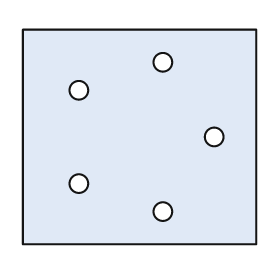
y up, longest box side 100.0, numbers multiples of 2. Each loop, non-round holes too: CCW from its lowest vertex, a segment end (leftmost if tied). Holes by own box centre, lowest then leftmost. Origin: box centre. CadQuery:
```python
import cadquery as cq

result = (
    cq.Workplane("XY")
    .moveTo(-50.0, -46.0)
    .lineTo(50.0, -46.0)
    .lineTo(50.0, 46.0)
    .lineTo(-50.0, 46.0)
    .close()
    .moveTo(10.0, -32.0)
    .circle(4.0)
    .moveTo(-26.0, -20.0)
    .circle(4.0)
    .moveTo(32.0, 0.0)
    .circle(4.0)
    .moveTo(-26.0, 20.0)
    .circle(4.0)
    .moveTo(10.0, 32.0)
    .circle(4.0)
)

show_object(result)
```